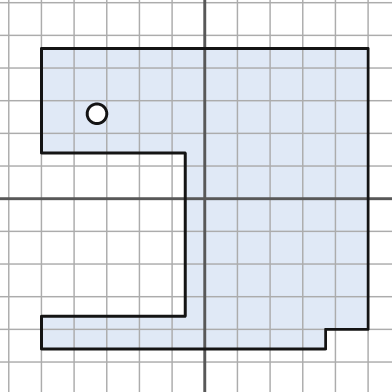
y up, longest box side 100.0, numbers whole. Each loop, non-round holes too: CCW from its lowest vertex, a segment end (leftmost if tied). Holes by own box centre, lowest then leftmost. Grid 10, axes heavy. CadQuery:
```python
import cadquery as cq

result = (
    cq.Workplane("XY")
    .moveTo(-50.0, -46.0)
    .lineTo(37.0, -46.0)
    .lineTo(37.0, -40.0)
    .lineTo(50.0, -40.0)
    .lineTo(50.0, 46.0)
    .lineTo(-50.0, 46.0)
    .lineTo(-50.0, 14.0)
    .lineTo(-6.0, 14.0)
    .lineTo(-6.0, -36.0)
    .lineTo(-50.0, -36.0)
    .close()
    .moveTo(-33.0, 26.0)
    .circle(3.0)
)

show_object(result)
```